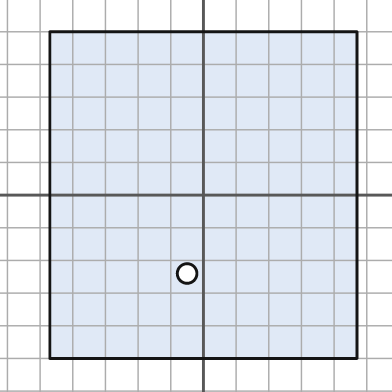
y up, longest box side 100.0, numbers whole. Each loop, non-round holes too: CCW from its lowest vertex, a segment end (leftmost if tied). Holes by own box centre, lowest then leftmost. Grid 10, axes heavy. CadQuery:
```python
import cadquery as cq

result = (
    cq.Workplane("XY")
    .moveTo(-47.0, -50.0)
    .lineTo(47.0, -50.0)
    .lineTo(47.0, 50.0)
    .lineTo(-47.0, 50.0)
    .close()
    .moveTo(-5.0, -24.0)
    .circle(3.0)
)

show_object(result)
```